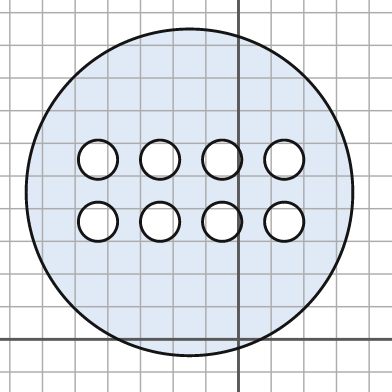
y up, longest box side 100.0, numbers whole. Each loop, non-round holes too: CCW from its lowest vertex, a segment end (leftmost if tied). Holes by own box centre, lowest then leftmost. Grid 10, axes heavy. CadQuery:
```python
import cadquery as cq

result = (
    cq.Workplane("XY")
    .moveTo(-15.0, 45.0)
    .circle(50.0)
    .moveTo(-43.0, 36.0)
    .circle(6.0)
    .moveTo(-24.0, 36.0)
    .circle(6.0)
    .moveTo(-5.0, 36.0)
    .circle(6.0)
    .moveTo(14.0, 36.0)
    .circle(6.0)
    .moveTo(-43.0, 55.0)
    .circle(6.0)
    .moveTo(-24.0, 55.0)
    .circle(6.0)
    .moveTo(-5.0, 55.0)
    .circle(6.0)
    .moveTo(14.0, 55.0)
    .circle(6.0)
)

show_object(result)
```